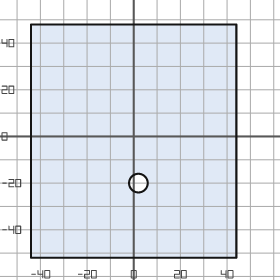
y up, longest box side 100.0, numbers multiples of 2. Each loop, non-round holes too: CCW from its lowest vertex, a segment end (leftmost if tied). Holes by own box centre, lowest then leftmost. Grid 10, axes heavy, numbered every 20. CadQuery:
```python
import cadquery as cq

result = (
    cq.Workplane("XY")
    .moveTo(-44.0, -52.0)
    .lineTo(44.0, -52.0)
    .lineTo(44.0, 48.0)
    .lineTo(-44.0, 48.0)
    .close()
    .moveTo(2.0, -20.0)
    .circle(4.0)
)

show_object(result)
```